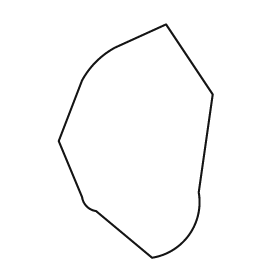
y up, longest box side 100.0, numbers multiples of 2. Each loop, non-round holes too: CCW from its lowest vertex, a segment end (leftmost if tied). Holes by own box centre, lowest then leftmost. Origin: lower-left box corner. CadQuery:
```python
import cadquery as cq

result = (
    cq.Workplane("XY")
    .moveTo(40.0, 0.0)
    .threePointArc((56.0, 10.0), (60.0, 28.0))
    .lineTo(66.0, 70.0)
    .lineTo(46.0, 100.0)
    .lineTo(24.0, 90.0)
    .threePointArc((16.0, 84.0), (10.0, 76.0))
    .lineTo(0.0, 50.0)
    .lineTo(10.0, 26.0)
    .threePointArc((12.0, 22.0), (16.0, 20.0))
    .close()
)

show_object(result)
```